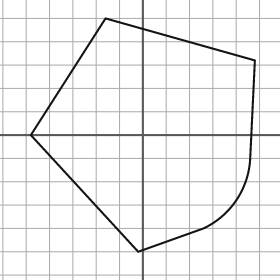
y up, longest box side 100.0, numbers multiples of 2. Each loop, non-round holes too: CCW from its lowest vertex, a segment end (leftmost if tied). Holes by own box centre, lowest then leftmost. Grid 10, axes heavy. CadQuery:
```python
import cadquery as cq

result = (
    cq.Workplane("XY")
    .moveTo(-2.0, -50.0)
    .lineTo(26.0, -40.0)
    .threePointArc((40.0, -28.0), (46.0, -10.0))
    .lineTo(48.0, 32.0)
    .lineTo(-16.0, 50.0)
    .lineTo(-48.0, 0.0)
    .close()
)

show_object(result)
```